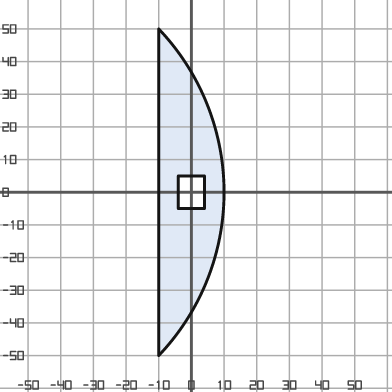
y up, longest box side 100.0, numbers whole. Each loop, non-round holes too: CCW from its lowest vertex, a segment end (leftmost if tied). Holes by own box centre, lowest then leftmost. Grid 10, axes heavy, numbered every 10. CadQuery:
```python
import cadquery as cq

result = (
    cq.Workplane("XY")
    .moveTo(-10.0, -50.0)
    .threePointArc((10.0, 0.0), (-10.0, 50.0))
    .close()
    .moveTo(-4.0, -5.0)
    .lineTo(4.0, -5.0)
    .lineTo(4.0, 5.0)
    .lineTo(-4.0, 5.0)
    .close()
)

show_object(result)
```